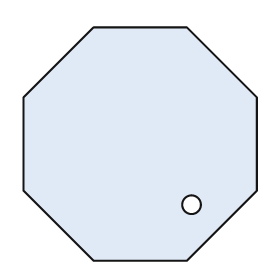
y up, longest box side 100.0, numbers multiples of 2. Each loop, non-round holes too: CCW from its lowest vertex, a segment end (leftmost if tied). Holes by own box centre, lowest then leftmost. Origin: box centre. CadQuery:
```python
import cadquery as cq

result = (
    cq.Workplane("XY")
    .moveTo(-20.0, -50.0)
    .lineTo(20.0, -50.0)
    .lineTo(50.0, -20.0)
    .lineTo(50.0, 20.0)
    .lineTo(20.0, 50.0)
    .lineTo(-20.0, 50.0)
    .lineTo(-50.0, 20.0)
    .lineTo(-50.0, -20.0)
    .close()
    .moveTo(22.0, -26.0)
    .circle(4.0)
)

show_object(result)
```